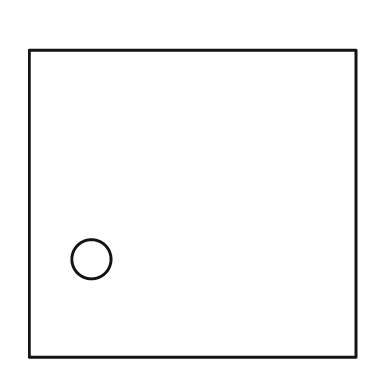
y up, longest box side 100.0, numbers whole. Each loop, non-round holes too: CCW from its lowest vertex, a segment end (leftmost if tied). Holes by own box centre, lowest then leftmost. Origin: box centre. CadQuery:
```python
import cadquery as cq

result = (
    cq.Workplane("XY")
    .moveTo(-50.0, -47.0)
    .lineTo(50.0, -47.0)
    .lineTo(50.0, 47.0)
    .lineTo(-50.0, 47.0)
    .close()
    .moveTo(-31.0, -17.0)
    .circle(6.0)
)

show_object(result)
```